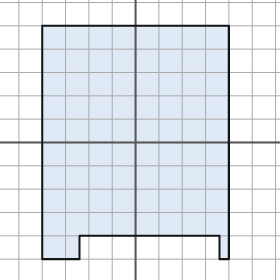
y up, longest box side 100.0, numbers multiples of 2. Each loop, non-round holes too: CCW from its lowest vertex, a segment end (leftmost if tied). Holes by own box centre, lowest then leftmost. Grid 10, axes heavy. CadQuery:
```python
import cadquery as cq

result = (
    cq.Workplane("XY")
    .moveTo(-40.0, -50.0)
    .lineTo(-24.0, -50.0)
    .lineTo(-24.0, -40.0)
    .lineTo(36.0, -40.0)
    .lineTo(36.0, -50.0)
    .lineTo(40.0, -50.0)
    .lineTo(40.0, 50.0)
    .lineTo(-40.0, 50.0)
    .close()
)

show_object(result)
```